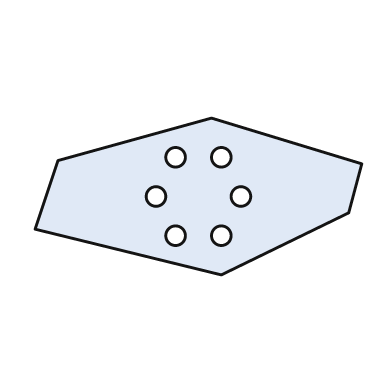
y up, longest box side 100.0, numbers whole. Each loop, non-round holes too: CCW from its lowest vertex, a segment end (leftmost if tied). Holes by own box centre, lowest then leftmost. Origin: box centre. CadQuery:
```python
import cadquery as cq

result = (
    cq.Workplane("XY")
    .moveTo(7.0, -24.0)
    .lineTo(46.0, -5.0)
    .lineTo(50.0, 10.0)
    .lineTo(4.0, 24.0)
    .lineTo(-43.0, 11.0)
    .lineTo(-50.0, -10.0)
    .close()
    .moveTo(-7.0, -12.0)
    .circle(3.0)
    .moveTo(7.0, -12.0)
    .circle(3.0)
    .moveTo(-13.0, 0.0)
    .circle(3.0)
    .moveTo(13.0, 0.0)
    .circle(3.0)
    .moveTo(-7.0, 12.0)
    .circle(3.0)
    .moveTo(7.0, 12.0)
    .circle(3.0)
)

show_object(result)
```